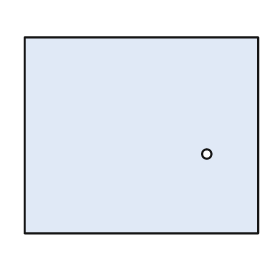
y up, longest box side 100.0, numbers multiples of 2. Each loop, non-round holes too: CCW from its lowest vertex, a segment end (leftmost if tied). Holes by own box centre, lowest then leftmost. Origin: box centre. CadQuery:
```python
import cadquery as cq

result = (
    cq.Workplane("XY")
    .moveTo(-50.0, -42.0)
    .lineTo(50.0, -42.0)
    .lineTo(50.0, 42.0)
    .lineTo(-50.0, 42.0)
    .close()
    .moveTo(28.0, -8.0)
    .circle(2.0)
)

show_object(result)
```